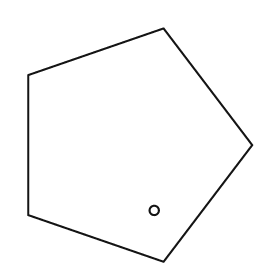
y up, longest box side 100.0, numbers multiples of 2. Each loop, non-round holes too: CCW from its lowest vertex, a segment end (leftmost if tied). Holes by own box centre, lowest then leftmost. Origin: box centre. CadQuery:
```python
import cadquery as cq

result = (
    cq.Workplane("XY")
    .moveTo(10.0, -50.0)
    .lineTo(48.0, 0.0)
    .lineTo(10.0, 50.0)
    .lineTo(-48.0, 30.0)
    .lineTo(-48.0, -30.0)
    .close()
    .moveTo(6.0, -28.0)
    .circle(2.0)
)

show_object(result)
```